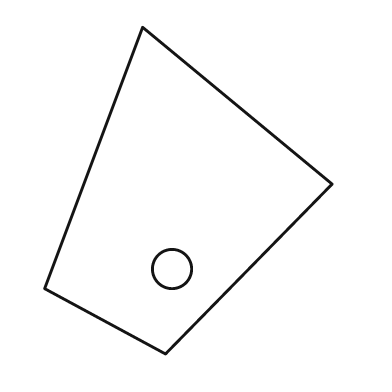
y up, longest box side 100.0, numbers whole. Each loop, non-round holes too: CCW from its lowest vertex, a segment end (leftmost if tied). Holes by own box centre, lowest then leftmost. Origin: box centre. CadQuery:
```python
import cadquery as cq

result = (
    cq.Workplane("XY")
    .moveTo(-7.0, -50.0)
    .lineTo(44.0, 2.0)
    .lineTo(-14.0, 50.0)
    .lineTo(-44.0, -30.0)
    .close()
    .moveTo(-5.0, -24.0)
    .circle(6.0)
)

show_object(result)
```